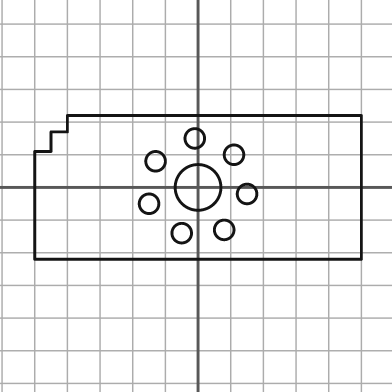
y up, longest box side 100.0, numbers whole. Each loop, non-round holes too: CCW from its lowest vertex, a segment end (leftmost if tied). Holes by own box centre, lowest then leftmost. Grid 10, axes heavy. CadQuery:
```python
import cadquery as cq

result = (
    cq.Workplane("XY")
    .moveTo(-50.0, -22.0)
    .lineTo(50.0, -22.0)
    .lineTo(50.0, 22.0)
    .lineTo(-40.0, 22.0)
    .lineTo(-40.0, 17.0)
    .lineTo(-45.0, 17.0)
    .lineTo(-45.0, 11.0)
    .lineTo(-50.0, 11.0)
    .close()
    .moveTo(-5.0, -14.0)
    .circle(3.0)
    .moveTo(8.0, -13.0)
    .circle(3.0)
    .moveTo(-15.0, -5.0)
    .circle(3.0)
    .moveTo(15.0, -2.0)
    .circle(3.0)
    .moveTo(0.0, 0.0)
    .circle(7.0)
    .moveTo(-13.0, 8.0)
    .circle(3.0)
    .moveTo(11.0, 10.0)
    .circle(3.0)
    .moveTo(-1.0, 15.0)
    .circle(3.0)
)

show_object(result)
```